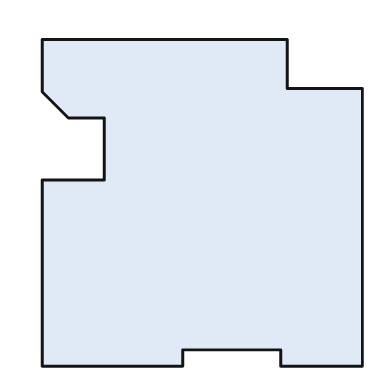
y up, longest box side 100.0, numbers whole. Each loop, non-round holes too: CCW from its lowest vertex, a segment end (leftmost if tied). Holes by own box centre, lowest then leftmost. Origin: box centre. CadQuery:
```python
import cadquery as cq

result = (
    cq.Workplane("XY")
    .moveTo(-49.0, -50.0)
    .lineTo(-6.0, -50.0)
    .lineTo(-6.0, -45.0)
    .lineTo(24.0, -45.0)
    .lineTo(24.0, -50.0)
    .lineTo(49.0, -50.0)
    .lineTo(49.0, 35.0)
    .lineTo(26.0, 35.0)
    .lineTo(26.0, 50.0)
    .lineTo(-49.0, 50.0)
    .lineTo(-49.0, 34.0)
    .lineTo(-41.0, 26.0)
    .lineTo(-30.0, 26.0)
    .lineTo(-30.0, 7.0)
    .lineTo(-49.0, 7.0)
    .close()
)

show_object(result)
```